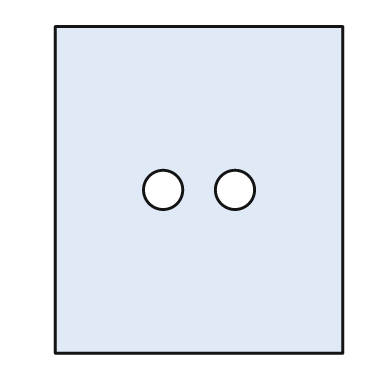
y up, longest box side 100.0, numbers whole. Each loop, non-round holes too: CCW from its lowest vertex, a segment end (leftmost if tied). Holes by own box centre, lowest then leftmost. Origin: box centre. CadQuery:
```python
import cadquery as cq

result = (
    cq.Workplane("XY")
    .moveTo(-44.0, -50.0)
    .lineTo(44.0, -50.0)
    .lineTo(44.0, 50.0)
    .lineTo(-44.0, 50.0)
    .close()
    .moveTo(-11.0, 0.0)
    .circle(6.0)
    .moveTo(11.0, 0.0)
    .circle(6.0)
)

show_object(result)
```